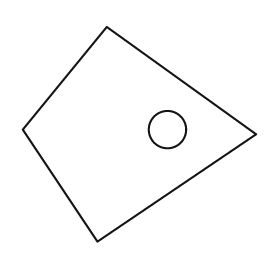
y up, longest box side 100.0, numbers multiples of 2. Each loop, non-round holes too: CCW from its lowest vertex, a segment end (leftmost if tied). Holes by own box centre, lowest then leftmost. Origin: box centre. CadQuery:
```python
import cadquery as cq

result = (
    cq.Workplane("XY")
    .moveTo(-18.0, -46.0)
    .lineTo(50.0, 0.0)
    .lineTo(-14.0, 46.0)
    .lineTo(-50.0, 2.0)
    .close()
    .moveTo(12.0, 2.0)
    .circle(8.0)
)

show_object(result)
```